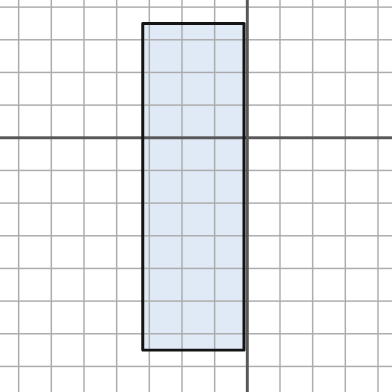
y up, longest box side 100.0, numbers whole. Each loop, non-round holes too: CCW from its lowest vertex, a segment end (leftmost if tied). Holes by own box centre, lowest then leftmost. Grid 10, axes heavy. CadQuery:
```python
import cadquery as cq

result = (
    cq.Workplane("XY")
    .moveTo(-32.0, -65.0)
    .lineTo(-1.0, -65.0)
    .lineTo(-1.0, 35.0)
    .lineTo(-32.0, 35.0)
    .close()
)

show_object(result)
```